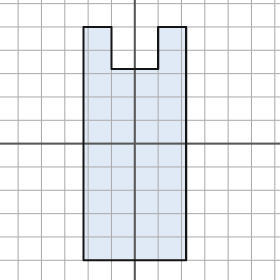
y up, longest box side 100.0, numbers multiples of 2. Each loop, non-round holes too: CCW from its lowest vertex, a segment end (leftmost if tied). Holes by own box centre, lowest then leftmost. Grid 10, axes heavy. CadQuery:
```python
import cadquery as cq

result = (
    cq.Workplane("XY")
    .moveTo(-22.0, -50.0)
    .lineTo(22.0, -50.0)
    .lineTo(22.0, 50.0)
    .lineTo(10.0, 50.0)
    .lineTo(10.0, 32.0)
    .lineTo(-10.0, 32.0)
    .lineTo(-10.0, 50.0)
    .lineTo(-22.0, 50.0)
    .close()
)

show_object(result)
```